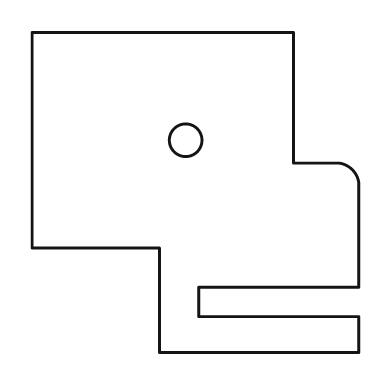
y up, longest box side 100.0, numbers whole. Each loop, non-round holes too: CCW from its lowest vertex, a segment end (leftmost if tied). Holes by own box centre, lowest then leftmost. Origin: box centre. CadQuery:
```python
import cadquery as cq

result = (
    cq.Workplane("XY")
    .moveTo(-11.0, -49.0)
    .lineTo(50.0, -49.0)
    .lineTo(50.0, -38.0)
    .lineTo(1.0, -38.0)
    .lineTo(1.0, -29.0)
    .lineTo(50.0, -29.0)
    .lineTo(50.0, 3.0)
    .threePointArc((48.0, 7.0), (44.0, 9.0))
    .lineTo(30.0, 9.0)
    .lineTo(30.0, 49.0)
    .lineTo(-50.0, 49.0)
    .lineTo(-50.0, -17.0)
    .lineTo(-11.0, -17.0)
    .close()
    .moveTo(-3.0, 16.0)
    .circle(5.0)
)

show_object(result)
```